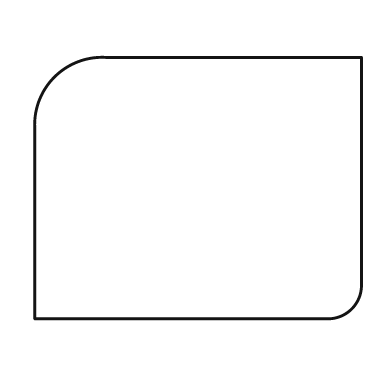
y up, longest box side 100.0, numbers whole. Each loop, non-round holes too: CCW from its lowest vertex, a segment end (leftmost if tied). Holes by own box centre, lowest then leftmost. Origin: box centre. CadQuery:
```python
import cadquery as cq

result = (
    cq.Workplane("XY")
    .moveTo(-50.0, -40.0)
    .lineTo(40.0, -40.0)
    .threePointArc((47.0, -37.0), (50.0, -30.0))
    .lineTo(50.0, 40.0)
    .lineTo(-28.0, 40.0)
    .threePointArc((-44.0, 34.0), (-50.0, 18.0))
    .close()
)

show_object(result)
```